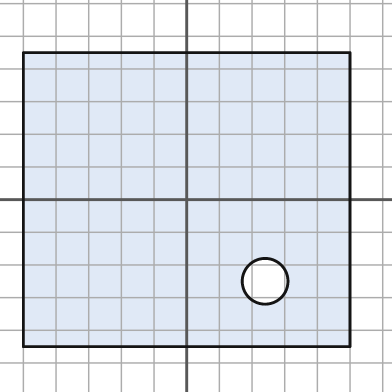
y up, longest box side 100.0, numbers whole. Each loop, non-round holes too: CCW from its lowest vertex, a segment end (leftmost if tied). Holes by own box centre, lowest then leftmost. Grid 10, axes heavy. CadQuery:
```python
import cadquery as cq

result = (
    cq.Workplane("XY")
    .moveTo(-50.0, -45.0)
    .lineTo(50.0, -45.0)
    .lineTo(50.0, 45.0)
    .lineTo(-50.0, 45.0)
    .close()
    .moveTo(24.0, -25.0)
    .circle(7.0)
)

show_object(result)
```